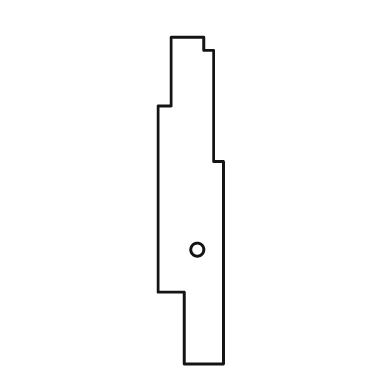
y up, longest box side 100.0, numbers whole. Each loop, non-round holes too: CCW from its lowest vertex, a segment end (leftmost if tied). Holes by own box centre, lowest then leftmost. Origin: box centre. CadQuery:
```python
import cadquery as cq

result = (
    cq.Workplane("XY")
    .moveTo(-2.0, -50.0)
    .lineTo(10.0, -50.0)
    .lineTo(10.0, 12.0)
    .lineTo(7.0, 12.0)
    .lineTo(7.0, 46.0)
    .lineTo(4.0, 46.0)
    .lineTo(4.0, 50.0)
    .lineTo(-6.0, 50.0)
    .lineTo(-6.0, 29.0)
    .lineTo(-10.0, 29.0)
    .lineTo(-10.0, -28.0)
    .lineTo(-2.0, -28.0)
    .close()
    .moveTo(2.0, -15.0)
    .circle(2.0)
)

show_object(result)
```